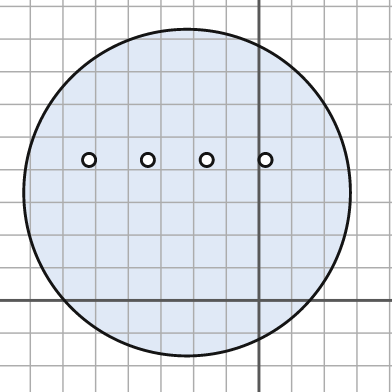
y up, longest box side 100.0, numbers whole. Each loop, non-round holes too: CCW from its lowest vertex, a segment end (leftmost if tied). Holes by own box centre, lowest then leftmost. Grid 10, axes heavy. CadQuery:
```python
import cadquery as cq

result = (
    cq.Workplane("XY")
    .moveTo(-22.0, 33.0)
    .circle(50.0)
    .moveTo(-52.0, 43.0)
    .circle(2.0)
    .moveTo(-34.0, 43.0)
    .circle(2.0)
    .moveTo(-16.0, 43.0)
    .circle(2.0)
    .moveTo(2.0, 43.0)
    .circle(2.0)
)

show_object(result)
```